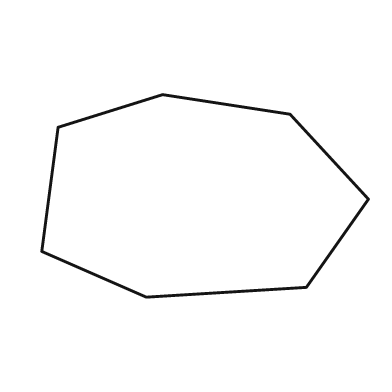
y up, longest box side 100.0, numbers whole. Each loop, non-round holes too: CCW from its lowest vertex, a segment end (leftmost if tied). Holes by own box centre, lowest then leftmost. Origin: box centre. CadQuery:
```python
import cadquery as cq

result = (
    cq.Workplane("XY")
    .moveTo(-18.0, -31.0)
    .lineTo(31.0, -28.0)
    .lineTo(50.0, -1.0)
    .lineTo(26.0, 25.0)
    .lineTo(-13.0, 31.0)
    .lineTo(-45.0, 21.0)
    .lineTo(-50.0, -17.0)
    .close()
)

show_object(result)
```